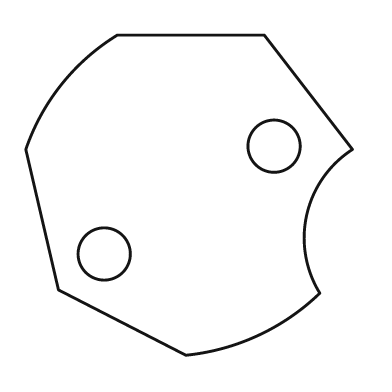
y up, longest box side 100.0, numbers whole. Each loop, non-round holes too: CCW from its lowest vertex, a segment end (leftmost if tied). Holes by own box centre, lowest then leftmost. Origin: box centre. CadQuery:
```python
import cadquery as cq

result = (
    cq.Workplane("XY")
    .moveTo(-1.0, -49.0)
    .threePointArc((21.0, -43.0), (40.0, -30.0))
    .threePointArc((36.0, -6.0), (50.0, 14.0))
    .lineTo(23.0, 49.0)
    .lineTo(-22.0, 49.0)
    .threePointArc((-39.0, 34.0), (-50.0, 14.0))
    .lineTo(-40.0, -29.0)
    .close()
    .moveTo(-26.0, -18.0)
    .circle(8.0)
    .moveTo(26.0, 15.0)
    .circle(8.0)
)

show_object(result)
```